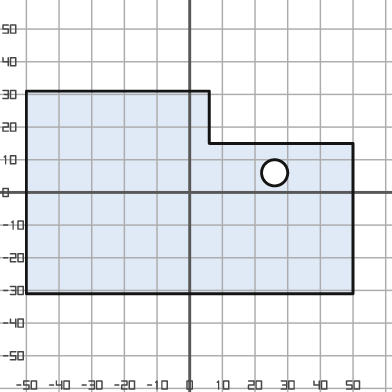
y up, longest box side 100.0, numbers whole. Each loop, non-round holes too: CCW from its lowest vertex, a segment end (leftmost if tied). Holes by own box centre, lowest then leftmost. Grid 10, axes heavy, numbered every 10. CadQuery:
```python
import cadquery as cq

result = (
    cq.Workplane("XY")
    .moveTo(-50.0, -31.0)
    .lineTo(50.0, -31.0)
    .lineTo(50.0, 15.0)
    .lineTo(6.0, 15.0)
    .lineTo(6.0, 31.0)
    .lineTo(-50.0, 31.0)
    .close()
    .moveTo(26.0, 6.0)
    .circle(4.0)
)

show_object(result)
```